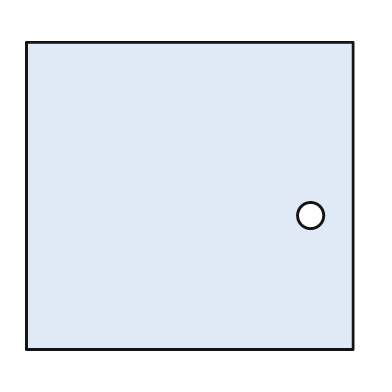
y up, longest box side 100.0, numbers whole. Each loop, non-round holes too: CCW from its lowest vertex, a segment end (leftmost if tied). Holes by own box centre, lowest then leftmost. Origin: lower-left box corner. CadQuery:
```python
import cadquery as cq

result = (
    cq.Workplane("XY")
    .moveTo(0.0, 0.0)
    .lineTo(100.0, 0.0)
    .lineTo(100.0, 94.0)
    .lineTo(0.0, 94.0)
    .close()
    .moveTo(87.0, 41.0)
    .circle(4.0)
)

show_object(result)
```